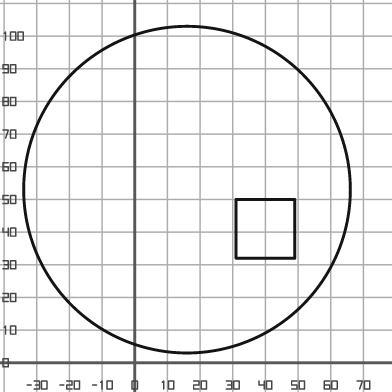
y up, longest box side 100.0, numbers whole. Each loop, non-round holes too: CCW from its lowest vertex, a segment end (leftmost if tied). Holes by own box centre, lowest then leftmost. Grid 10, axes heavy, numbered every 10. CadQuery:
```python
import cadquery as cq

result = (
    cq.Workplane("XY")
    .moveTo(16.0, 53.0)
    .circle(50.0)
    .moveTo(31.0, 32.0)
    .lineTo(49.0, 32.0)
    .lineTo(49.0, 50.0)
    .lineTo(31.0, 50.0)
    .close()
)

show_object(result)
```